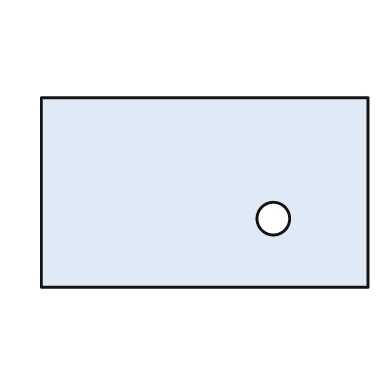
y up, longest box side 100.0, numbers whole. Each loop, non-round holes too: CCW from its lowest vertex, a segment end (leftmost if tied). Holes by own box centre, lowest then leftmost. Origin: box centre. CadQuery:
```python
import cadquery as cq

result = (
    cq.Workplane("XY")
    .moveTo(-50.0, -29.0)
    .lineTo(50.0, -29.0)
    .lineTo(50.0, 29.0)
    .lineTo(-50.0, 29.0)
    .close()
    .moveTo(21.0, -8.0)
    .circle(5.0)
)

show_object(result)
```